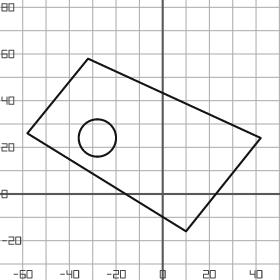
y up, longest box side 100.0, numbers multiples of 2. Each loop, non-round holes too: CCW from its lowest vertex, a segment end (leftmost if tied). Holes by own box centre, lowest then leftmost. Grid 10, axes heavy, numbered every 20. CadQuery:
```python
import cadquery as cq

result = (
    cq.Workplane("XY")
    .moveTo(10.0, -16.0)
    .lineTo(42.0, 24.0)
    .lineTo(-32.0, 58.0)
    .lineTo(-58.0, 26.0)
    .close()
    .moveTo(-28.0, 24.0)
    .circle(8.0)
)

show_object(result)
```